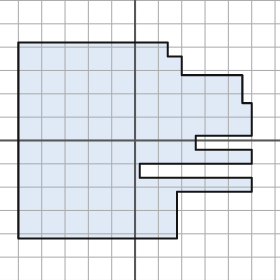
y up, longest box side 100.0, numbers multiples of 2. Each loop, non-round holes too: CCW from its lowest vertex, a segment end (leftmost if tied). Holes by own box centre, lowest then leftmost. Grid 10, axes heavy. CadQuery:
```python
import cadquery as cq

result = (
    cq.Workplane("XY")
    .moveTo(-50.0, -42.0)
    .lineTo(18.0, -42.0)
    .lineTo(18.0, -22.0)
    .lineTo(50.0, -22.0)
    .lineTo(50.0, -16.0)
    .lineTo(2.0, -16.0)
    .lineTo(2.0, -10.0)
    .lineTo(50.0, -10.0)
    .lineTo(50.0, -4.0)
    .lineTo(26.0, -4.0)
    .lineTo(26.0, 2.0)
    .lineTo(50.0, 2.0)
    .lineTo(50.0, 16.0)
    .lineTo(46.0, 16.0)
    .lineTo(46.0, 28.0)
    .lineTo(20.0, 28.0)
    .lineTo(20.0, 36.0)
    .lineTo(14.0, 36.0)
    .lineTo(14.0, 42.0)
    .lineTo(-50.0, 42.0)
    .close()
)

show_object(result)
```